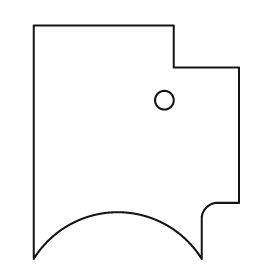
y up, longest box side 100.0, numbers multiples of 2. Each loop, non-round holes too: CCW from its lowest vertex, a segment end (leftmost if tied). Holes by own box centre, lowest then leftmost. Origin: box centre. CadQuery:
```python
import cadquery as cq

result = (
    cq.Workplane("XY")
    .moveTo(-44.0, -50.0)
    .threePointArc((-8.0, -30.0), (28.0, -50.0))
    .lineTo(28.0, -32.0)
    .threePointArc((30.0, -28.0), (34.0, -26.0))
    .lineTo(44.0, -26.0)
    .lineTo(44.0, 32.0)
    .lineTo(16.0, 32.0)
    .lineTo(16.0, 50.0)
    .lineTo(-44.0, 50.0)
    .close()
    .moveTo(12.0, 18.0)
    .circle(4.0)
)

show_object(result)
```